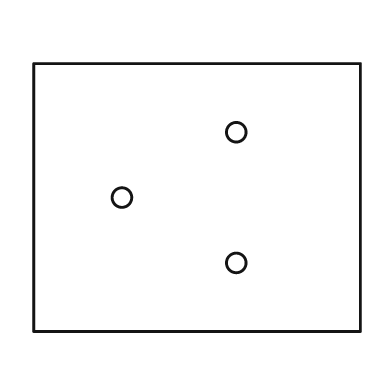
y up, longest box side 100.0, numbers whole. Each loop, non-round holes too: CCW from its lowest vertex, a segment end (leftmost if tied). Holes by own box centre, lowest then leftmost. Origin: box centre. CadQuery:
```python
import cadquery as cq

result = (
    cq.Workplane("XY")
    .moveTo(-50.0, -41.0)
    .lineTo(50.0, -41.0)
    .lineTo(50.0, 41.0)
    .lineTo(-50.0, 41.0)
    .close()
    .moveTo(12.0, -20.0)
    .circle(3.0)
    .moveTo(-23.0, 0.0)
    .circle(3.0)
    .moveTo(12.0, 20.0)
    .circle(3.0)
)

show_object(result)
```